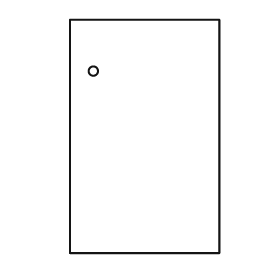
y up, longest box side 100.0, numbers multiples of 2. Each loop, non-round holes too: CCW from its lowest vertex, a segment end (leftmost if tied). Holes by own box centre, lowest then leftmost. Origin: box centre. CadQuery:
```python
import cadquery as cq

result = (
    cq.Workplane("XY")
    .moveTo(-32.0, -50.0)
    .lineTo(32.0, -50.0)
    .lineTo(32.0, 50.0)
    .lineTo(-32.0, 50.0)
    .close()
    .moveTo(-22.0, 28.0)
    .circle(2.0)
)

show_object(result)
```